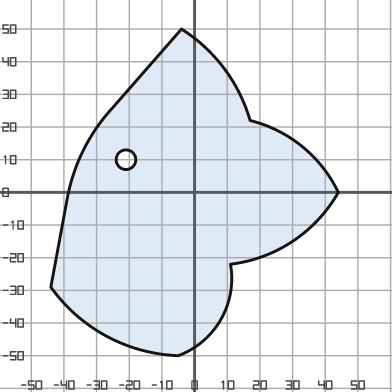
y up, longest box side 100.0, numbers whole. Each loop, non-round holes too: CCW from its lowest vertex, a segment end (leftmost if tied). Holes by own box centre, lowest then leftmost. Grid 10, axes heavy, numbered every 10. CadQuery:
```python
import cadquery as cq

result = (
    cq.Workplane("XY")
    .moveTo(-5.0, -50.0)
    .threePointArc((8.0, -39.0), (11.0, -22.0))
    .threePointArc((30.0, -15.0), (44.0, 0.0))
    .threePointArc((33.0, 14.0), (17.0, 22.0))
    .threePointArc((9.0, 38.0), (-4.0, 50.0))
    .lineTo(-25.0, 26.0)
    .threePointArc((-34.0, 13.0), (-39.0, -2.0))
    .lineTo(-44.0, -29.0)
    .threePointArc((-27.0, -44.0), (-5.0, -50.0))
    .close()
    .moveTo(-21.0, 10.0)
    .circle(3.0)
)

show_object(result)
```